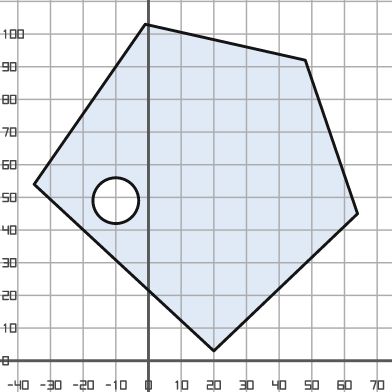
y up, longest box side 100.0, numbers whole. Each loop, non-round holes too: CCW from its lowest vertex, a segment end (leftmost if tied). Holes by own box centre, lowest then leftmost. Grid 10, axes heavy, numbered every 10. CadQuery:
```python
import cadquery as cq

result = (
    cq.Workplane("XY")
    .moveTo(20.0, 3.0)
    .lineTo(64.0, 45.0)
    .lineTo(48.0, 92.0)
    .lineTo(-1.0, 103.0)
    .lineTo(-35.0, 54.0)
    .close()
    .moveTo(-10.0, 49.0)
    .circle(7.0)
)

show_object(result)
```